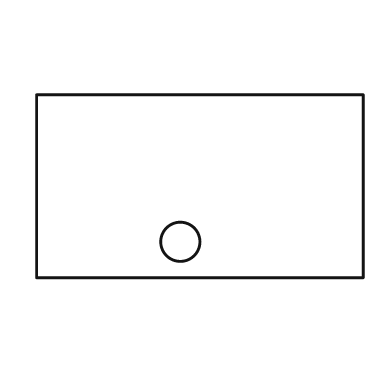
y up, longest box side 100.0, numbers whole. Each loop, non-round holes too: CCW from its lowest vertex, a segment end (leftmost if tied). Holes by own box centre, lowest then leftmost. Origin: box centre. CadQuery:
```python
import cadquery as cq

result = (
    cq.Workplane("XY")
    .moveTo(-50.0, -28.0)
    .lineTo(50.0, -28.0)
    .lineTo(50.0, 28.0)
    .lineTo(-50.0, 28.0)
    .close()
    .moveTo(-6.0, -17.0)
    .circle(6.0)
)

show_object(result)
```